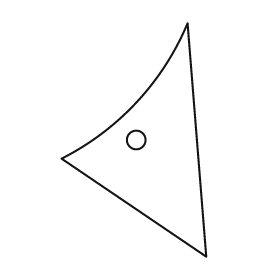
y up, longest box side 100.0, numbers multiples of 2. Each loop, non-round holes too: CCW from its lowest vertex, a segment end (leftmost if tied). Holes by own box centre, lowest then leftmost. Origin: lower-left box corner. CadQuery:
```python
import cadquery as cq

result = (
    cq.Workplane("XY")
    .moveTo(62.0, 0.0)
    .lineTo(54.0, 100.0)
    .threePointArc((32.0, 66.0), (0.0, 42.0))
    .close()
    .moveTo(32.0, 50.0)
    .circle(4.0)
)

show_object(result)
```